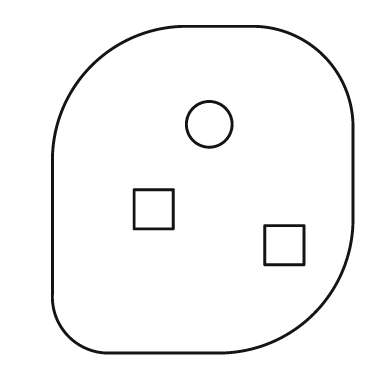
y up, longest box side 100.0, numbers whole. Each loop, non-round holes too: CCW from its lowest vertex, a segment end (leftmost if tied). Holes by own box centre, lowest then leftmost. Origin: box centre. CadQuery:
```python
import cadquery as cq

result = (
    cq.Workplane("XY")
    .moveTo(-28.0, -50.0)
    .lineTo(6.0, -50.0)
    .threePointArc((34.0, -38.0), (46.0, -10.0))
    .lineTo(46.0, 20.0)
    .threePointArc((37.0, 41.0), (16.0, 50.0))
    .lineTo(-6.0, 50.0)
    .threePointArc((-34.0, 38.0), (-46.0, 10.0))
    .lineTo(-46.0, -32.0)
    .threePointArc((-41.0, -45.0), (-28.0, -50.0))
    .close()
    .moveTo(19.0, -23.0)
    .lineTo(31.0, -23.0)
    .lineTo(31.0, -11.0)
    .lineTo(19.0, -11.0)
    .close()
    .moveTo(-21.0, -12.0)
    .lineTo(-9.0, -12.0)
    .lineTo(-9.0, 0.0)
    .lineTo(-21.0, 0.0)
    .close()
    .moveTo(2.0, 20.0)
    .circle(7.0)
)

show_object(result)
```